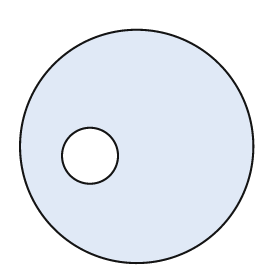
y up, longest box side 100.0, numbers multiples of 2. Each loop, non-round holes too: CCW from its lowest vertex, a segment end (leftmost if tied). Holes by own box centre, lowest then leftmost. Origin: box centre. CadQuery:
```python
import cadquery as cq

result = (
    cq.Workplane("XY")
    .moveTo(0.0, 0.0)
    .circle(50.0)
    .moveTo(-20.0, -4.0)
    .circle(12.0)
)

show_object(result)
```